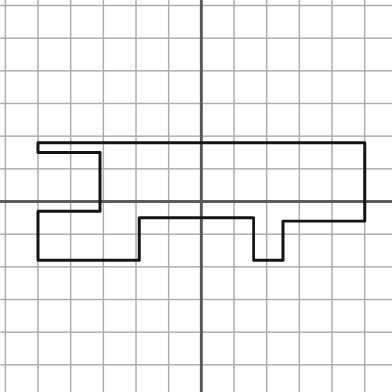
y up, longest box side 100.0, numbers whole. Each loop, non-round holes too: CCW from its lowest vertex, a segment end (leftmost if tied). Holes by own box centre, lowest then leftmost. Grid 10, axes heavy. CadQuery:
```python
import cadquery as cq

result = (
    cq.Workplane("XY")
    .moveTo(-50.0, -18.0)
    .lineTo(-19.0, -18.0)
    .lineTo(-19.0, -5.0)
    .lineTo(16.0, -5.0)
    .lineTo(16.0, -18.0)
    .lineTo(25.0, -18.0)
    .lineTo(25.0, -6.0)
    .lineTo(50.0, -6.0)
    .lineTo(50.0, 18.0)
    .lineTo(-50.0, 18.0)
    .lineTo(-50.0, 15.0)
    .lineTo(-31.0, 15.0)
    .lineTo(-31.0, -3.0)
    .lineTo(-50.0, -3.0)
    .close()
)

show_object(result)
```